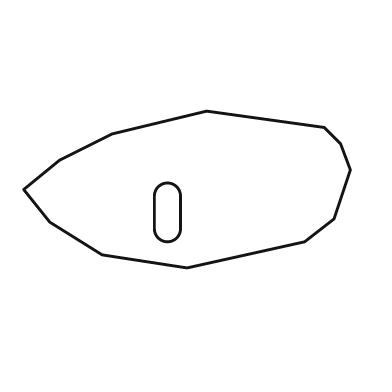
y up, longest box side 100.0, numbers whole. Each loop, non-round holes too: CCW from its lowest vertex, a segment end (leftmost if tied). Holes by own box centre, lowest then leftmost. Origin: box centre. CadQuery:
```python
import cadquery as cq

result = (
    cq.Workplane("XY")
    .moveTo(0.0, -24.0)
    .lineTo(36.0, -16.0)
    .lineTo(45.0, -9.0)
    .lineTo(50.0, 6.0)
    .lineTo(47.0, 14.0)
    .lineTo(42.0, 19.0)
    .lineTo(6.0, 24.0)
    .lineTo(-23.0, 17.0)
    .lineTo(-39.0, 9.0)
    .lineTo(-50.0, 0.0)
    .lineTo(-42.0, -10.0)
    .lineTo(-26.0, -20.0)
    .close()
    .moveTo(-10.0, -12.0)
    .threePointArc((-6.0, -16.0), (-2.0, -12.0))
    .lineTo(-2.0, -2.0)
    .threePointArc((-6.0, 2.0), (-10.0, -2.0))
    .close()
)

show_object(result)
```